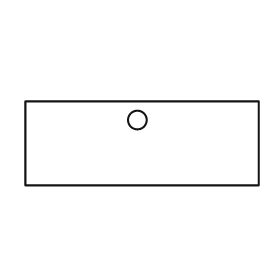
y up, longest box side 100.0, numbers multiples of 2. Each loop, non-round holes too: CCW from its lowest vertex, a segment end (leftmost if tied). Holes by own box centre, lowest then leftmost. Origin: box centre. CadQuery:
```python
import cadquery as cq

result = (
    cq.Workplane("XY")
    .moveTo(-50.0, -18.0)
    .lineTo(50.0, -18.0)
    .lineTo(50.0, 18.0)
    .lineTo(-50.0, 18.0)
    .close()
    .moveTo(-2.0, 10.0)
    .circle(4.0)
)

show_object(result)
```